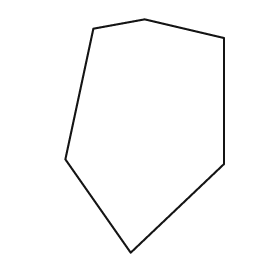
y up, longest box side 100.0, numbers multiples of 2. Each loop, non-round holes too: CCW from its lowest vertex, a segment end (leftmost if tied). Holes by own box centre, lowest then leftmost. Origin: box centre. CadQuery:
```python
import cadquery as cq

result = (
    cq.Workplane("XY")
    .moveTo(-6.0, -50.0)
    .lineTo(34.0, -12.0)
    .lineTo(34.0, 42.0)
    .lineTo(0.0, 50.0)
    .lineTo(-22.0, 46.0)
    .lineTo(-34.0, -10.0)
    .close()
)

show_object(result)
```